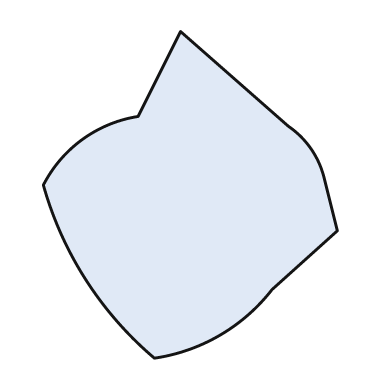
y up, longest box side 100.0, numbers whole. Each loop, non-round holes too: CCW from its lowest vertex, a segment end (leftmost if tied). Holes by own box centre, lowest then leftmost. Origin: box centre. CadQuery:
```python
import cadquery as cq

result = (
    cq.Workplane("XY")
    .moveTo(-11.0, -50.0)
    .threePointArc((9.0, -43.0), (25.0, -29.0))
    .lineTo(45.0, -11.0)
    .lineTo(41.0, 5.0)
    .threePointArc((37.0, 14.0), (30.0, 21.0))
    .lineTo(-3.0, 50.0)
    .lineTo(-16.0, 24.0)
    .threePointArc((-33.0, 17.0), (-45.0, 3.0))
    .threePointArc((-32.0, -26.0), (-11.0, -50.0))
    .close()
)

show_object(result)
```